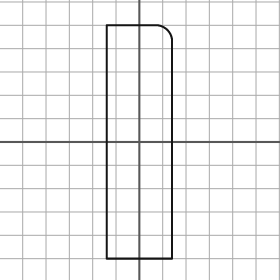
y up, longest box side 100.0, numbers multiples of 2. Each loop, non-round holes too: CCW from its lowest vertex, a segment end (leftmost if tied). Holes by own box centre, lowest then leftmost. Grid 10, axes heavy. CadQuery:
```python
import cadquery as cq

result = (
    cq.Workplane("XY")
    .moveTo(-14.0, -50.0)
    .lineTo(14.0, -50.0)
    .lineTo(14.0, 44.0)
    .threePointArc((12.0, 48.0), (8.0, 50.0))
    .lineTo(-14.0, 50.0)
    .close()
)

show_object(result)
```